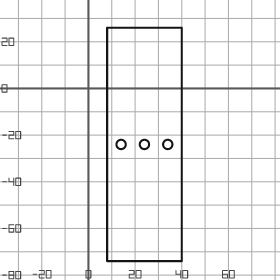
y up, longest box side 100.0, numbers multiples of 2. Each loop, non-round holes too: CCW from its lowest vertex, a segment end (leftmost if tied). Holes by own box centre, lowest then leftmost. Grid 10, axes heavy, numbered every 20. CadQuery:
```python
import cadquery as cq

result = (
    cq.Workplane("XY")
    .moveTo(8.0, -74.0)
    .lineTo(40.0, -74.0)
    .lineTo(40.0, 26.0)
    .lineTo(8.0, 26.0)
    .close()
    .moveTo(14.0, -24.0)
    .circle(2.0)
    .moveTo(24.0, -24.0)
    .circle(2.0)
    .moveTo(34.0, -24.0)
    .circle(2.0)
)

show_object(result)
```